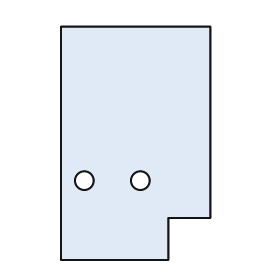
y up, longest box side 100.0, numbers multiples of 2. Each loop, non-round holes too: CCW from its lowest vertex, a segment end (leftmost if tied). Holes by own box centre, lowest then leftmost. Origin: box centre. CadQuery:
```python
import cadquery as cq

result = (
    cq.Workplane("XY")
    .moveTo(-32.0, -50.0)
    .lineTo(14.0, -50.0)
    .lineTo(14.0, -32.0)
    .lineTo(32.0, -32.0)
    .lineTo(32.0, 50.0)
    .lineTo(-32.0, 50.0)
    .close()
    .moveTo(-22.0, -16.0)
    .circle(4.0)
    .moveTo(2.0, -16.0)
    .circle(4.0)
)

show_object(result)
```